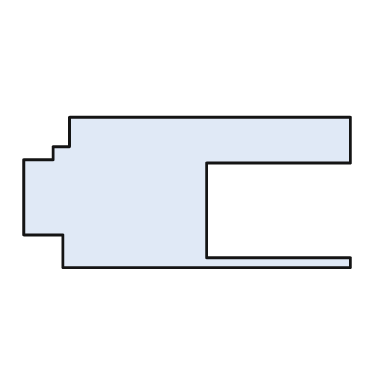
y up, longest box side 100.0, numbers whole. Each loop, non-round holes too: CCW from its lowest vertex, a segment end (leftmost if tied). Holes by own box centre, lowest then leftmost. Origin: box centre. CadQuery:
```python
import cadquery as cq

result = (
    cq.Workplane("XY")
    .moveTo(-38.0, -23.0)
    .lineTo(50.0, -23.0)
    .lineTo(50.0, -20.0)
    .lineTo(6.0, -20.0)
    .lineTo(6.0, 9.0)
    .lineTo(50.0, 9.0)
    .lineTo(50.0, 23.0)
    .lineTo(-36.0, 23.0)
    .lineTo(-36.0, 14.0)
    .lineTo(-41.0, 14.0)
    .lineTo(-41.0, 10.0)
    .lineTo(-50.0, 10.0)
    .lineTo(-50.0, -13.0)
    .lineTo(-38.0, -13.0)
    .close()
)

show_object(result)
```